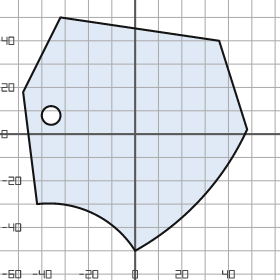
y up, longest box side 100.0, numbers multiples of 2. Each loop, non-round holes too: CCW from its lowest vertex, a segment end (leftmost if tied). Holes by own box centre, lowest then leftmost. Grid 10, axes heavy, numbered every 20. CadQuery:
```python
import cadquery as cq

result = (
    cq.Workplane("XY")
    .moveTo(0.0, -50.0)
    .threePointArc((28.0, -28.0), (48.0, 2.0))
    .lineTo(36.0, 40.0)
    .lineTo(-32.0, 50.0)
    .lineTo(-48.0, 18.0)
    .lineTo(-42.0, -30.0)
    .threePointArc((-18.0, -34.0), (0.0, -50.0))
    .close()
    .moveTo(-36.0, 8.0)
    .circle(4.0)
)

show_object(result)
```